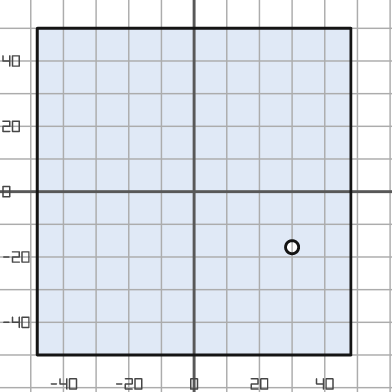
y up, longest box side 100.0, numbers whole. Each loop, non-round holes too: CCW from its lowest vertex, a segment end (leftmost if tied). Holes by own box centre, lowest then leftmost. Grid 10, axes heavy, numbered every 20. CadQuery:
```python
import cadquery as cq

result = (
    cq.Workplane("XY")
    .moveTo(-48.0, -50.0)
    .lineTo(48.0, -50.0)
    .lineTo(48.0, 50.0)
    .lineTo(-48.0, 50.0)
    .close()
    .moveTo(30.0, -17.0)
    .circle(2.0)
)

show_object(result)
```